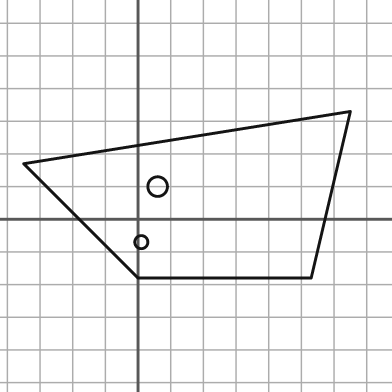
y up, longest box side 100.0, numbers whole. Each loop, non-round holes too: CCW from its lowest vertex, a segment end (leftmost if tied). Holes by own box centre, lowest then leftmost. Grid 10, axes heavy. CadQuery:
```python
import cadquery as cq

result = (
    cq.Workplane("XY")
    .moveTo(0.0, -18.0)
    .lineTo(53.0, -18.0)
    .lineTo(65.0, 33.0)
    .lineTo(-35.0, 17.0)
    .close()
    .moveTo(1.0, -7.0)
    .circle(2.0)
    .moveTo(6.0, 10.0)
    .circle(3.0)
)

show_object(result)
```